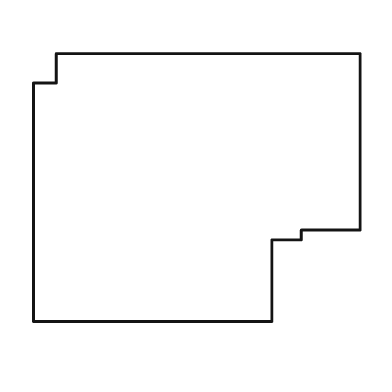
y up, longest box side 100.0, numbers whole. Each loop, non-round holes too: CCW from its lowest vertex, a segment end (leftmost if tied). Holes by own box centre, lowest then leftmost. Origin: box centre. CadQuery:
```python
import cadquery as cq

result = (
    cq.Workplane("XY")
    .moveTo(-50.0, -41.0)
    .lineTo(23.0, -41.0)
    .lineTo(23.0, -16.0)
    .lineTo(32.0, -16.0)
    .lineTo(32.0, -13.0)
    .lineTo(50.0, -13.0)
    .lineTo(50.0, 41.0)
    .lineTo(-43.0, 41.0)
    .lineTo(-43.0, 32.0)
    .lineTo(-50.0, 32.0)
    .close()
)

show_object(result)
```